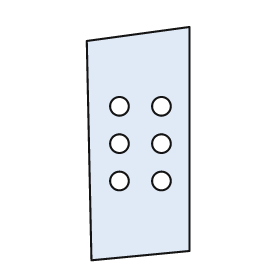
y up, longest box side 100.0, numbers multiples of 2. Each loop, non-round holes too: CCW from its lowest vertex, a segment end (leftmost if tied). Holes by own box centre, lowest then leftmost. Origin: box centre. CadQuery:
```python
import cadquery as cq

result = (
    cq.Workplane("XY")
    .moveTo(-20.0, -50.0)
    .lineTo(22.0, -46.0)
    .lineTo(22.0, 50.0)
    .lineTo(-22.0, 44.0)
    .close()
    .moveTo(-8.0, -16.0)
    .circle(4.0)
    .moveTo(10.0, -16.0)
    .circle(4.0)
    .moveTo(-8.0, 0.0)
    .circle(4.0)
    .moveTo(10.0, 0.0)
    .circle(4.0)
    .moveTo(-8.0, 16.0)
    .circle(4.0)
    .moveTo(10.0, 16.0)
    .circle(4.0)
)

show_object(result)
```